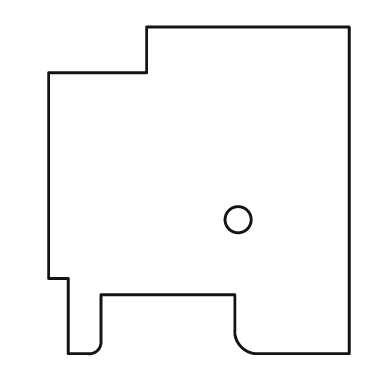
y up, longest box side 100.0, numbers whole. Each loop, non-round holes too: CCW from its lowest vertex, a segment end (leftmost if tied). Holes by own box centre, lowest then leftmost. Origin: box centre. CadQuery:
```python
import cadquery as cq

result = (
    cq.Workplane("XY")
    .moveTo(-40.0, -50.0)
    .lineTo(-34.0, -50.0)
    .threePointArc((-31.0, -49.0), (-30.0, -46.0))
    .lineTo(-30.0, -32.0)
    .lineTo(11.0, -32.0)
    .lineTo(11.0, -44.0)
    .threePointArc((13.0, -48.0), (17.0, -50.0))
    .lineTo(46.0, -50.0)
    .lineTo(46.0, 50.0)
    .lineTo(-16.0, 50.0)
    .lineTo(-16.0, 36.0)
    .lineTo(-46.0, 36.0)
    .lineTo(-46.0, -27.0)
    .lineTo(-40.0, -27.0)
    .close()
    .moveTo(12.0, -9.0)
    .circle(4.0)
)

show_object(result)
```